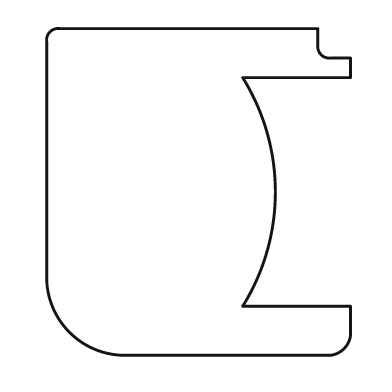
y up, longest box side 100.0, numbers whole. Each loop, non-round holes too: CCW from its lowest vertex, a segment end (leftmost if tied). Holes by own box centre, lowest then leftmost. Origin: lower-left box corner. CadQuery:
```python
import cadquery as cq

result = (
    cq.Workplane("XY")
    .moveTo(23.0, 0.0)
    .lineTo(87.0, 0.0)
    .threePointArc((91.0, 2.0), (93.0, 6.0))
    .lineTo(93.0, 15.0)
    .lineTo(60.0, 15.0)
    .threePointArc((70.0, 50.0), (60.0, 85.0))
    .lineTo(93.0, 85.0)
    .lineTo(93.0, 91.0)
    .lineTo(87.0, 91.0)
    .threePointArc((84.0, 92.0), (83.0, 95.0))
    .lineTo(83.0, 100.0)
    .lineTo(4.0, 100.0)
    .threePointArc((1.0, 99.0), (0.0, 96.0))
    .lineTo(0.0, 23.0)
    .threePointArc((7.0, 7.0), (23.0, 0.0))
    .close()
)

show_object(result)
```